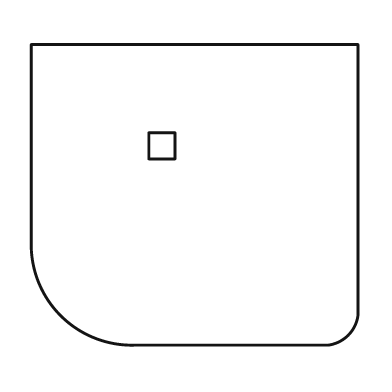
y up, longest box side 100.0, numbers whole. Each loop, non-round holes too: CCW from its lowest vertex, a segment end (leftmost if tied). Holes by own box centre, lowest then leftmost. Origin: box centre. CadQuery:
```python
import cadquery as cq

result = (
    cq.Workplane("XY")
    .moveTo(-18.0, -46.0)
    .lineTo(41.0, -46.0)
    .threePointArc((47.0, -43.0), (50.0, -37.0))
    .lineTo(50.0, 46.0)
    .lineTo(-50.0, 46.0)
    .lineTo(-50.0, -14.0)
    .threePointArc((-41.0, -37.0), (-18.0, -46.0))
    .close()
    .moveTo(-14.0, 11.0)
    .lineTo(-6.0, 11.0)
    .lineTo(-6.0, 19.0)
    .lineTo(-14.0, 19.0)
    .close()
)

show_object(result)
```